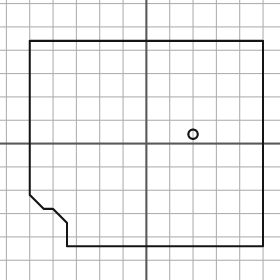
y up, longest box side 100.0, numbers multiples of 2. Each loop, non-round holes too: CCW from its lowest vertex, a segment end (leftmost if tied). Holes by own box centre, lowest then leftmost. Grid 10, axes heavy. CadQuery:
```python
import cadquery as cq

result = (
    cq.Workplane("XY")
    .moveTo(-34.0, -44.0)
    .lineTo(50.0, -44.0)
    .lineTo(50.0, 44.0)
    .lineTo(-50.0, 44.0)
    .lineTo(-50.0, -22.0)
    .lineTo(-44.0, -28.0)
    .lineTo(-40.0, -28.0)
    .lineTo(-34.0, -34.0)
    .close()
    .moveTo(20.0, 4.0)
    .circle(2.0)
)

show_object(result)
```